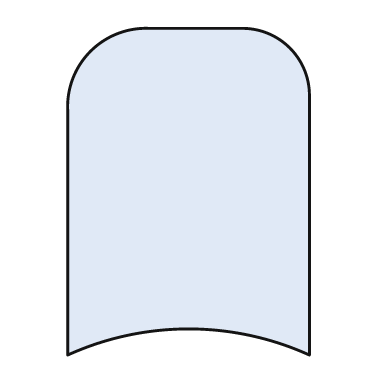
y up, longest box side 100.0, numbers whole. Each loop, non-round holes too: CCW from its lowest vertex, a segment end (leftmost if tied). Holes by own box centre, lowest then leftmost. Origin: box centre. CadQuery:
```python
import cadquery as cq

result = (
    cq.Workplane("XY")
    .moveTo(-37.0, -50.0)
    .threePointArc((0.0, -42.0), (37.0, -50.0))
    .lineTo(37.0, 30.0)
    .threePointArc((31.0, 44.0), (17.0, 50.0))
    .lineTo(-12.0, 50.0)
    .threePointArc((-30.0, 43.0), (-37.0, 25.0))
    .close()
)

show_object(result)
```